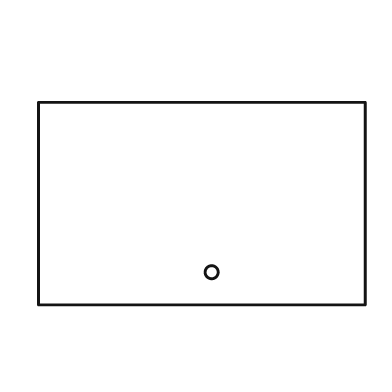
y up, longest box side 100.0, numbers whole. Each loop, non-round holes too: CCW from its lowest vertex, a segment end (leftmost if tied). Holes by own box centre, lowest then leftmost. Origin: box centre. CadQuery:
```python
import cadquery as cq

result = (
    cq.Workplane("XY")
    .moveTo(-50.0, -31.0)
    .lineTo(50.0, -31.0)
    .lineTo(50.0, 31.0)
    .lineTo(-50.0, 31.0)
    .close()
    .moveTo(3.0, -21.0)
    .circle(2.0)
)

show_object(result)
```